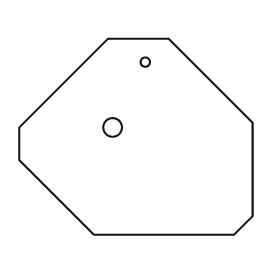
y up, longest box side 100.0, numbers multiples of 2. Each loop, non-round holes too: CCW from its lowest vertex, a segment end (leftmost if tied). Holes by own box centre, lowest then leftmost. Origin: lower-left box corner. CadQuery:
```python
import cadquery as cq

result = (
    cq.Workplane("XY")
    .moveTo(32.0, 0.0)
    .lineTo(92.0, 0.0)
    .lineTo(100.0, 8.0)
    .lineTo(100.0, 48.0)
    .lineTo(64.0, 84.0)
    .lineTo(38.0, 84.0)
    .lineTo(0.0, 46.0)
    .lineTo(0.0, 32.0)
    .close()
    .moveTo(40.0, 46.0)
    .circle(4.0)
    .moveTo(54.0, 74.0)
    .circle(2.0)
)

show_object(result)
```